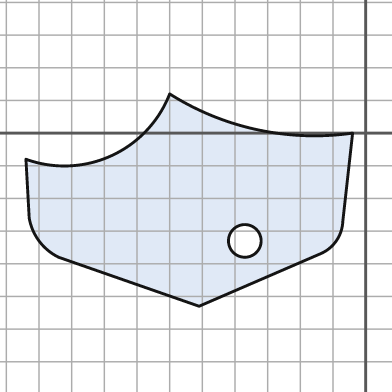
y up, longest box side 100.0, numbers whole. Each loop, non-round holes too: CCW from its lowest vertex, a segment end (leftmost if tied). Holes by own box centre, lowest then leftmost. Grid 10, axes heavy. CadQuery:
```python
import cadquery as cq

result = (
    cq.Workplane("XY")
    .moveTo(-51.0, -53.0)
    .lineTo(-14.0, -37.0)
    .threePointArc((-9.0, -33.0), (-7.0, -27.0))
    .lineTo(-4.0, 0.0)
    .threePointArc((-33.0, 1.0), (-60.0, 12.0))
    .threePointArc((-78.0, -7.0), (-104.0, -8.0))
    .lineTo(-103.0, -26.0)
    .threePointArc((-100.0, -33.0), (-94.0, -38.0))
    .close()
    .moveTo(-37.0, -33.0)
    .circle(5.0)
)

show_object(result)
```